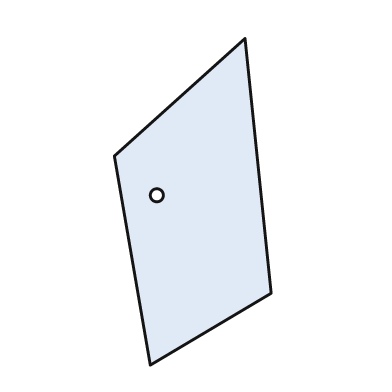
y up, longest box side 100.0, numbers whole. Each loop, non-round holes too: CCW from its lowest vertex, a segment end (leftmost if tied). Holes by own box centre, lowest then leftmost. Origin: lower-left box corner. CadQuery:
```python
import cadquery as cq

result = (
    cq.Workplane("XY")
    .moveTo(11.0, 0.0)
    .lineTo(48.0, 22.0)
    .lineTo(40.0, 100.0)
    .lineTo(0.0, 64.0)
    .close()
    .moveTo(13.0, 52.0)
    .circle(2.0)
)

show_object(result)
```